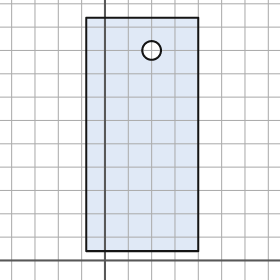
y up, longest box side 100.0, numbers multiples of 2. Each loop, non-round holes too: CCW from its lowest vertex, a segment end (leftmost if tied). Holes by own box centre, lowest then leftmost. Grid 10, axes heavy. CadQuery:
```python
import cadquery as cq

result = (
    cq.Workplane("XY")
    .moveTo(-8.0, 4.0)
    .lineTo(40.0, 4.0)
    .lineTo(40.0, 104.0)
    .lineTo(-8.0, 104.0)
    .close()
    .moveTo(20.0, 90.0)
    .circle(4.0)
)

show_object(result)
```